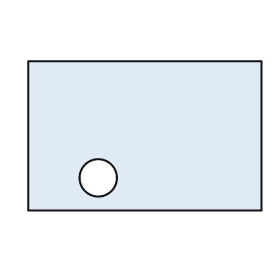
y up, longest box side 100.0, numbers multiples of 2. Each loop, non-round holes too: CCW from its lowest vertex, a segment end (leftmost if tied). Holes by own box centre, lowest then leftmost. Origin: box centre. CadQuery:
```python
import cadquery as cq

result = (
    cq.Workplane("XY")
    .moveTo(-50.0, -32.0)
    .lineTo(50.0, -32.0)
    .lineTo(50.0, 32.0)
    .lineTo(-50.0, 32.0)
    .close()
    .moveTo(-20.0, -18.0)
    .circle(8.0)
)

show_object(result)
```